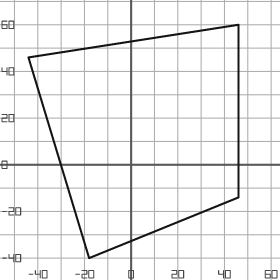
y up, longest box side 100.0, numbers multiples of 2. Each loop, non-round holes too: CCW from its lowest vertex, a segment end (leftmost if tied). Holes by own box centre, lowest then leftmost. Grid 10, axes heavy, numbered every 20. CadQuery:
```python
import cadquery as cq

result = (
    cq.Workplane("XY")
    .moveTo(-18.0, -40.0)
    .lineTo(46.0, -14.0)
    .lineTo(46.0, 60.0)
    .lineTo(-44.0, 46.0)
    .close()
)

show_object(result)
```